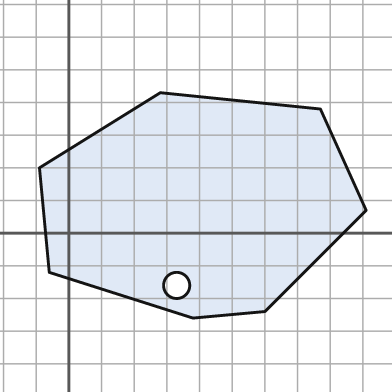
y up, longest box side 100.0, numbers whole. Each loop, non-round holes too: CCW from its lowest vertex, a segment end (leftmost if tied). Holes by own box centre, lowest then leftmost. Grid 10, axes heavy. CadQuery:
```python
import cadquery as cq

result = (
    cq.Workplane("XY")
    .moveTo(38.0, -26.0)
    .lineTo(60.0, -24.0)
    .lineTo(91.0, 7.0)
    .lineTo(77.0, 38.0)
    .lineTo(28.0, 43.0)
    .lineTo(-9.0, 20.0)
    .lineTo(-6.0, -12.0)
    .close()
    .moveTo(33.0, -16.0)
    .circle(4.0)
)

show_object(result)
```